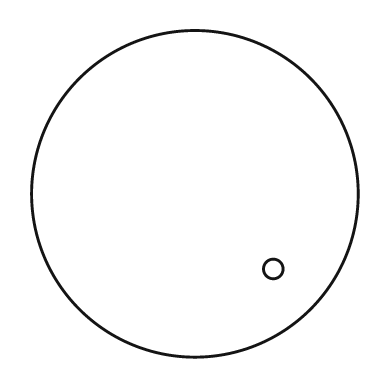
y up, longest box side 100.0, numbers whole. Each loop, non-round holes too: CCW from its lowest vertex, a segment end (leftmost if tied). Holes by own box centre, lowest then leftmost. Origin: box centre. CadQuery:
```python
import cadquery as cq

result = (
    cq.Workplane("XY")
    .moveTo(0.0, 0.0)
    .circle(50.0)
    .moveTo(24.0, -23.0)
    .circle(3.0)
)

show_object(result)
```